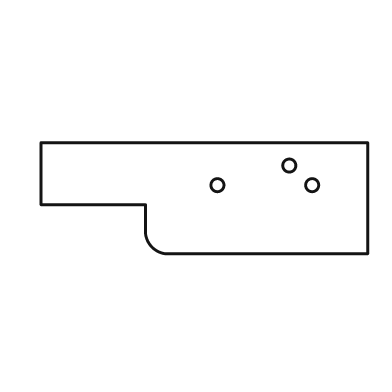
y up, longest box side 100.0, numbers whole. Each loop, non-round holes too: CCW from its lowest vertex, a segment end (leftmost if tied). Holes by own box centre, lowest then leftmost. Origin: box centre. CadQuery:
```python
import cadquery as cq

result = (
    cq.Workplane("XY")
    .moveTo(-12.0, -17.0)
    .lineTo(50.0, -17.0)
    .lineTo(50.0, 17.0)
    .lineTo(-50.0, 17.0)
    .lineTo(-50.0, -2.0)
    .lineTo(-18.0, -2.0)
    .lineTo(-18.0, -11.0)
    .threePointArc((-16.0, -15.0), (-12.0, -17.0))
    .close()
    .moveTo(4.0, 4.0)
    .circle(2.0)
    .moveTo(33.0, 4.0)
    .circle(2.0)
    .moveTo(26.0, 10.0)
    .circle(2.0)
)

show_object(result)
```